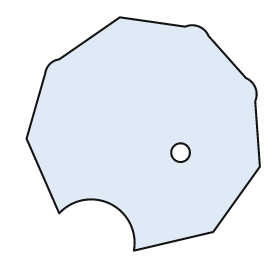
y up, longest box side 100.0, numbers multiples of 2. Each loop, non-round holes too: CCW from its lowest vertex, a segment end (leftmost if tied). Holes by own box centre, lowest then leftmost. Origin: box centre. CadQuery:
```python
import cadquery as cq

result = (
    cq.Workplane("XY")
    .moveTo(-4.0, -50.0)
    .lineTo(30.0, -42.0)
    .lineTo(50.0, -14.0)
    .lineTo(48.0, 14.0)
    .threePointArc((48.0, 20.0), (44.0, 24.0))
    .lineTo(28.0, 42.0)
    .threePointArc((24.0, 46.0), (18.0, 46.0))
    .lineTo(-10.0, 50.0)
    .lineTo(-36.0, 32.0)
    .threePointArc((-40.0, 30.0), (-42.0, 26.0))
    .lineTo(-50.0, -2.0)
    .lineTo(-36.0, -34.0)
    .threePointArc((-14.0, -30.0), (-4.0, -50.0))
    .close()
    .moveTo(16.0, -8.0)
    .circle(4.0)
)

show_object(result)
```